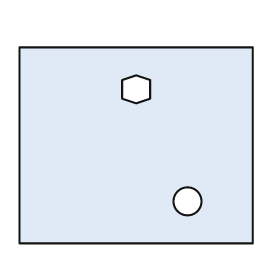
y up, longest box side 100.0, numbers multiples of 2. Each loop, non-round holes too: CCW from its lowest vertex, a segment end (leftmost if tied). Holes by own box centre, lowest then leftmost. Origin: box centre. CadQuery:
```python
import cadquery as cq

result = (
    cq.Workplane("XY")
    .moveTo(-50.0, -42.0)
    .lineTo(50.0, -42.0)
    .lineTo(50.0, 42.0)
    .lineTo(-50.0, 42.0)
    .close()
    .moveTo(22.0, -24.0)
    .circle(6.0)
    .moveTo(0.0, 18.0)
    .lineTo(6.0, 20.0)
    .lineTo(6.0, 28.0)
    .lineTo(0.0, 30.0)
    .lineTo(-6.0, 28.0)
    .lineTo(-6.0, 20.0)
    .close()
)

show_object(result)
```